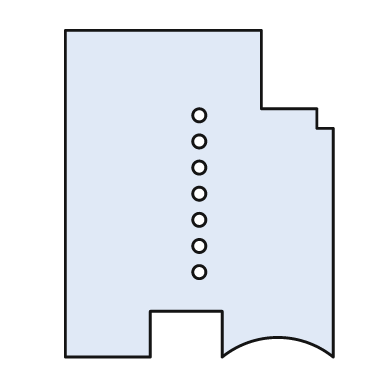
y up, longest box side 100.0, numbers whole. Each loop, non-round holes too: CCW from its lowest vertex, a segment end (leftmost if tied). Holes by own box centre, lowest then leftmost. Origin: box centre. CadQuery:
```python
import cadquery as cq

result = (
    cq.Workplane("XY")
    .moveTo(-41.0, -50.0)
    .lineTo(-15.0, -50.0)
    .lineTo(-15.0, -36.0)
    .lineTo(7.0, -36.0)
    .lineTo(7.0, -50.0)
    .threePointArc((24.0, -44.0), (41.0, -50.0))
    .lineTo(41.0, 20.0)
    .lineTo(36.0, 20.0)
    .lineTo(36.0, 26.0)
    .lineTo(19.0, 26.0)
    .lineTo(19.0, 50.0)
    .lineTo(-41.0, 50.0)
    .close()
    .moveTo(0.0, -24.0)
    .circle(2.0)
    .moveTo(0.0, -16.0)
    .circle(2.0)
    .moveTo(0.0, -8.0)
    .circle(2.0)
    .moveTo(0.0, 0.0)
    .circle(2.0)
    .moveTo(0.0, 8.0)
    .circle(2.0)
    .moveTo(0.0, 16.0)
    .circle(2.0)
    .moveTo(0.0, 24.0)
    .circle(2.0)
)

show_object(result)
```